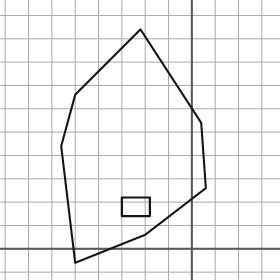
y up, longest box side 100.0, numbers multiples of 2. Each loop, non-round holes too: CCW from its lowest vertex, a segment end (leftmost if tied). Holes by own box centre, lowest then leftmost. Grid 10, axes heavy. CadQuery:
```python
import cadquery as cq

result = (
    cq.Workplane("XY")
    .moveTo(-50.0, -6.0)
    .lineTo(-20.0, 6.0)
    .lineTo(6.0, 26.0)
    .lineTo(4.0, 54.0)
    .lineTo(-22.0, 94.0)
    .lineTo(-50.0, 66.0)
    .lineTo(-56.0, 44.0)
    .close()
    .moveTo(-30.0, 14.0)
    .lineTo(-18.0, 14.0)
    .lineTo(-18.0, 22.0)
    .lineTo(-30.0, 22.0)
    .close()
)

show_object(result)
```